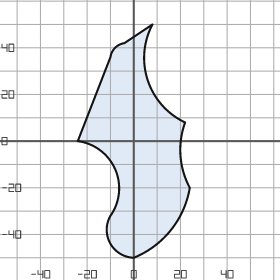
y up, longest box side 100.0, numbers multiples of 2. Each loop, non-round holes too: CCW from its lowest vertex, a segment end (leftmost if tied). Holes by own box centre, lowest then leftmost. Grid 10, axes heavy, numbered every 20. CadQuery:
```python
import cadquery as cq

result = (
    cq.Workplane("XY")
    .moveTo(0.0, -50.0)
    .threePointArc((16.0, -38.0), (24.0, -20.0))
    .threePointArc((20.0, -6.0), (22.0, 8.0))
    .threePointArc((6.0, 26.0), (8.0, 50.0))
    .lineTo(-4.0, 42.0)
    .threePointArc((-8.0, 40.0), (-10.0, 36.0))
    .lineTo(-24.0, 0.0)
    .threePointArc((-8.0, -12.0), (-10.0, -32.0))
    .threePointArc((-10.0, -44.0), (0.0, -50.0))
    .close()
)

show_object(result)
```